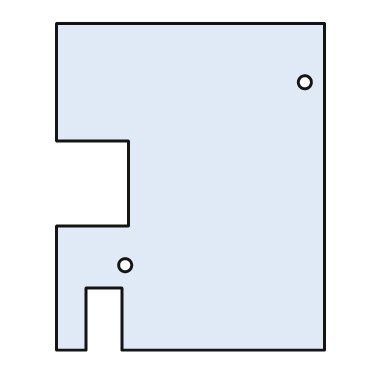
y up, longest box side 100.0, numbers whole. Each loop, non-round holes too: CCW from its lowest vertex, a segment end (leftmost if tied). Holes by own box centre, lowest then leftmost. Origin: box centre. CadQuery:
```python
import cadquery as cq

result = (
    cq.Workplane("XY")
    .moveTo(-41.0, -50.0)
    .lineTo(-32.0, -50.0)
    .lineTo(-32.0, -31.0)
    .lineTo(-21.0, -31.0)
    .lineTo(-21.0, -50.0)
    .lineTo(41.0, -50.0)
    .lineTo(41.0, 50.0)
    .lineTo(-41.0, 50.0)
    .lineTo(-41.0, 14.0)
    .lineTo(-19.0, 14.0)
    .lineTo(-19.0, -12.0)
    .lineTo(-41.0, -12.0)
    .close()
    .moveTo(-20.0, -24.0)
    .circle(2.0)
    .moveTo(35.0, 32.0)
    .circle(2.0)
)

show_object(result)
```